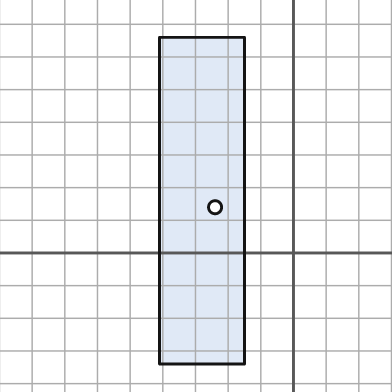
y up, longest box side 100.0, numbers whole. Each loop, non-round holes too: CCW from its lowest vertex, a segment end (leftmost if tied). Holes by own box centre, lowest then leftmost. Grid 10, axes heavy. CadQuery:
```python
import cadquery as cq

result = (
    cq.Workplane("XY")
    .moveTo(-41.0, -34.0)
    .lineTo(-15.0, -34.0)
    .lineTo(-15.0, 66.0)
    .lineTo(-41.0, 66.0)
    .close()
    .moveTo(-24.0, 14.0)
    .circle(2.0)
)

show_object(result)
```